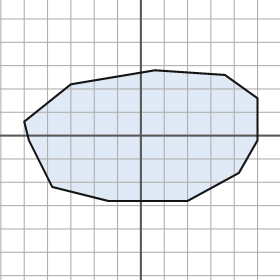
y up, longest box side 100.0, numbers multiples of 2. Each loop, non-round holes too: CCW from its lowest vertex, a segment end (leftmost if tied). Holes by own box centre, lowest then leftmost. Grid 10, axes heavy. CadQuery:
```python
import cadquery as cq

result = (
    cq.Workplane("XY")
    .moveTo(-14.0, -28.0)
    .lineTo(20.0, -28.0)
    .lineTo(42.0, -16.0)
    .lineTo(50.0, -2.0)
    .lineTo(50.0, 16.0)
    .lineTo(36.0, 26.0)
    .lineTo(6.0, 28.0)
    .lineTo(-30.0, 22.0)
    .lineTo(-50.0, 6.0)
    .lineTo(-48.0, -2.0)
    .lineTo(-38.0, -22.0)
    .close()
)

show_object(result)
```